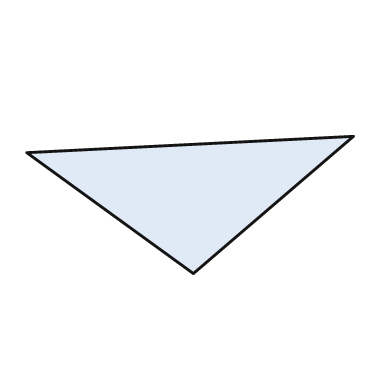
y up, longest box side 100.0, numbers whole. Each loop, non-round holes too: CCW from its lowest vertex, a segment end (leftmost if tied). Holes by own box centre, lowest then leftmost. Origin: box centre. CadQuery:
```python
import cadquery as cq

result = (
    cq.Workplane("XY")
    .moveTo(1.0, -21.0)
    .lineTo(50.0, 21.0)
    .lineTo(-50.0, 16.0)
    .close()
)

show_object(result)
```